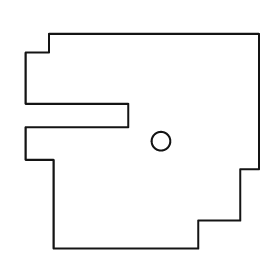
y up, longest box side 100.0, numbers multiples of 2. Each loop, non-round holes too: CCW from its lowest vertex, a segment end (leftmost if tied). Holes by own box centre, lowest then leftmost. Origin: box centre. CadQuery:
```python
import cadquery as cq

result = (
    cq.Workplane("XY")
    .moveTo(-38.0, -46.0)
    .lineTo(24.0, -46.0)
    .lineTo(24.0, -34.0)
    .lineTo(42.0, -34.0)
    .lineTo(42.0, -12.0)
    .lineTo(50.0, -12.0)
    .lineTo(50.0, 46.0)
    .lineTo(-40.0, 46.0)
    .lineTo(-40.0, 38.0)
    .lineTo(-50.0, 38.0)
    .lineTo(-50.0, 16.0)
    .lineTo(-6.0, 16.0)
    .lineTo(-6.0, 6.0)
    .lineTo(-50.0, 6.0)
    .lineTo(-50.0, -8.0)
    .lineTo(-38.0, -8.0)
    .close()
    .moveTo(8.0, 0.0)
    .circle(4.0)
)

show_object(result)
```